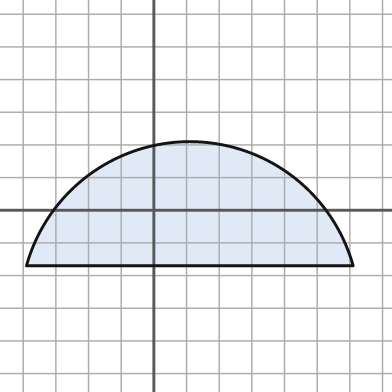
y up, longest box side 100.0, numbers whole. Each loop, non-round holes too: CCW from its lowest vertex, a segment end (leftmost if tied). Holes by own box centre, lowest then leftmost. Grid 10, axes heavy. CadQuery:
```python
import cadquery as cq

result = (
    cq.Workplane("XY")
    .moveTo(-39.0, -17.0)
    .lineTo(61.0, -17.0)
    .threePointArc((11.0, 21.0), (-39.0, -17.0))
    .close()
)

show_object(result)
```